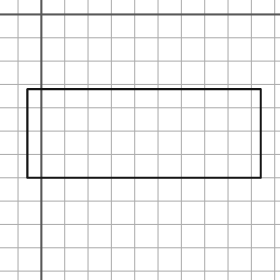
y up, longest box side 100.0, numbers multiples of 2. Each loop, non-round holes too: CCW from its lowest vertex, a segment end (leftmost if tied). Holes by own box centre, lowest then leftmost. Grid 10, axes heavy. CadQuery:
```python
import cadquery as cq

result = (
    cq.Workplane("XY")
    .moveTo(-6.0, -70.0)
    .lineTo(94.0, -70.0)
    .lineTo(94.0, -32.0)
    .lineTo(-6.0, -32.0)
    .close()
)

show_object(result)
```